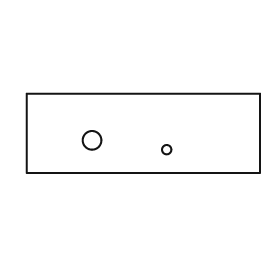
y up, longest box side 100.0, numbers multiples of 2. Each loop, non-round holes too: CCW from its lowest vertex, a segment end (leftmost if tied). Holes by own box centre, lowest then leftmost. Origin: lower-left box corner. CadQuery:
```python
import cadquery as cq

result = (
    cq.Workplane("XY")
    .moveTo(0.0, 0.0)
    .lineTo(100.0, 0.0)
    .lineTo(100.0, 34.0)
    .lineTo(0.0, 34.0)
    .close()
    .moveTo(60.0, 10.0)
    .circle(2.0)
    .moveTo(28.0, 14.0)
    .circle(4.0)
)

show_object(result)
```